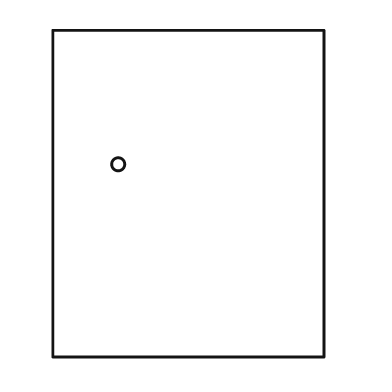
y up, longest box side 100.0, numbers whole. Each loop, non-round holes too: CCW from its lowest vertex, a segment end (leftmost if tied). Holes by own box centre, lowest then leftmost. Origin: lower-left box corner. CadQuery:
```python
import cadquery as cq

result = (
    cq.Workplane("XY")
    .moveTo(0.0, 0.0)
    .lineTo(83.0, 0.0)
    .lineTo(83.0, 100.0)
    .lineTo(0.0, 100.0)
    .close()
    .moveTo(20.0, 59.0)
    .circle(2.0)
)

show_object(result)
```